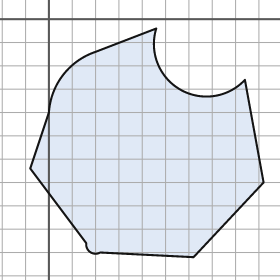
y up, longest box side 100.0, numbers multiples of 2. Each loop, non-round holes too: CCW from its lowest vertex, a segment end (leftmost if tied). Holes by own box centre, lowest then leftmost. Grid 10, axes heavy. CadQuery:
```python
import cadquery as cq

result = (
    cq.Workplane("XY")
    .moveTo(62.0, -102.0)
    .lineTo(92.0, -70.0)
    .lineTo(84.0, -26.0)
    .threePointArc((56.0, -30.0), (46.0, -4.0))
    .lineTo(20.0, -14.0)
    .threePointArc((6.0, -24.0), (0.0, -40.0))
    .lineTo(-8.0, -64.0)
    .lineTo(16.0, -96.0)
    .threePointArc((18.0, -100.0), (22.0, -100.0))
    .close()
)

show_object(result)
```